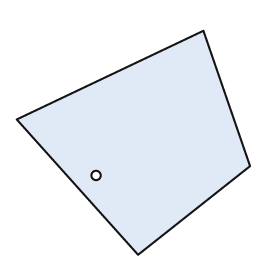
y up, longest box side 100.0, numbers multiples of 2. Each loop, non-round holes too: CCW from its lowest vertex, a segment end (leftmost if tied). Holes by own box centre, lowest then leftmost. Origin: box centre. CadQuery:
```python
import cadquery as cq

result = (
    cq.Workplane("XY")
    .moveTo(2.0, -48.0)
    .lineTo(50.0, -10.0)
    .lineTo(30.0, 48.0)
    .lineTo(-50.0, 10.0)
    .close()
    .moveTo(-16.0, -14.0)
    .circle(2.0)
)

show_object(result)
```